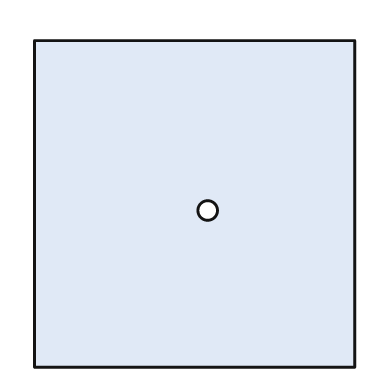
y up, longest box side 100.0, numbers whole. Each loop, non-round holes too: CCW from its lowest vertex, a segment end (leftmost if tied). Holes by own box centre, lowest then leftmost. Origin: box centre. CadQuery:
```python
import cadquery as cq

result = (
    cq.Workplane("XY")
    .moveTo(-49.0, -50.0)
    .lineTo(49.0, -50.0)
    .lineTo(49.0, 50.0)
    .lineTo(-49.0, 50.0)
    .close()
    .moveTo(4.0, -2.0)
    .circle(3.0)
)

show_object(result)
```